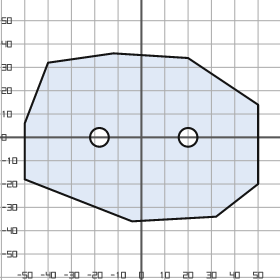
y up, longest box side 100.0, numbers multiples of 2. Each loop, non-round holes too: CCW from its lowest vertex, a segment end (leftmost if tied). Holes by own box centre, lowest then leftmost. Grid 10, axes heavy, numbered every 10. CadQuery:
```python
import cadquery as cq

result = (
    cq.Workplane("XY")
    .moveTo(-4.0, -36.0)
    .lineTo(32.0, -34.0)
    .lineTo(50.0, -20.0)
    .lineTo(50.0, 14.0)
    .lineTo(20.0, 34.0)
    .lineTo(-12.0, 36.0)
    .lineTo(-40.0, 32.0)
    .lineTo(-50.0, 6.0)
    .lineTo(-50.0, -18.0)
    .close()
    .moveTo(-18.0, 0.0)
    .circle(4.0)
    .moveTo(20.0, 0.0)
    .circle(4.0)
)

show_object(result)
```